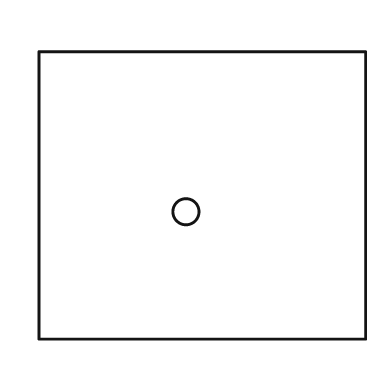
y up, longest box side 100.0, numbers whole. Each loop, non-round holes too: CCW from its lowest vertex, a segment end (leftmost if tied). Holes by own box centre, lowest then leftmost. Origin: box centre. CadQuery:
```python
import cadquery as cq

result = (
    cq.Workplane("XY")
    .moveTo(-50.0, -44.0)
    .lineTo(50.0, -44.0)
    .lineTo(50.0, 44.0)
    .lineTo(-50.0, 44.0)
    .close()
    .moveTo(-5.0, -5.0)
    .circle(4.0)
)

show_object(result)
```